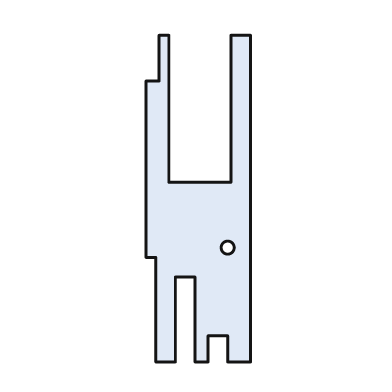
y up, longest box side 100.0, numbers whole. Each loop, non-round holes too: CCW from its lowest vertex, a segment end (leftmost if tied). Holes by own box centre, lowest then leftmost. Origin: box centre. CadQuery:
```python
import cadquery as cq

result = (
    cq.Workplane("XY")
    .moveTo(-13.0, -50.0)
    .lineTo(-7.0, -50.0)
    .lineTo(-7.0, -24.0)
    .lineTo(-1.0, -24.0)
    .lineTo(-1.0, -50.0)
    .lineTo(3.0, -50.0)
    .lineTo(3.0, -42.0)
    .lineTo(9.0, -42.0)
    .lineTo(9.0, -50.0)
    .lineTo(16.0, -50.0)
    .lineTo(16.0, 50.0)
    .lineTo(10.0, 50.0)
    .lineTo(10.0, 5.0)
    .lineTo(-9.0, 5.0)
    .lineTo(-9.0, 50.0)
    .lineTo(-12.0, 50.0)
    .lineTo(-12.0, 36.0)
    .lineTo(-16.0, 36.0)
    .lineTo(-16.0, -18.0)
    .lineTo(-13.0, -18.0)
    .close()
    .moveTo(9.0, -15.0)
    .circle(2.0)
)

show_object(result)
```